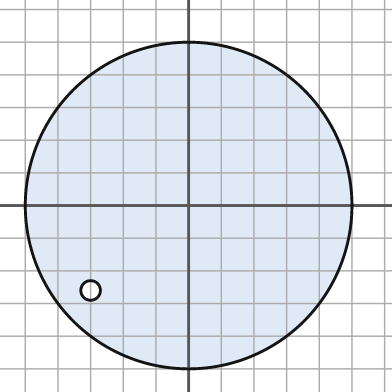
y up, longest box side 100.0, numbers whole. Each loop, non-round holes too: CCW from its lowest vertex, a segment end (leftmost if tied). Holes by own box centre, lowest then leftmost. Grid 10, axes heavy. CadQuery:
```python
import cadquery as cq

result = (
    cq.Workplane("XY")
    .moveTo(0.0, 0.0)
    .circle(50.0)
    .moveTo(-30.0, -26.0)
    .circle(3.0)
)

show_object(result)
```